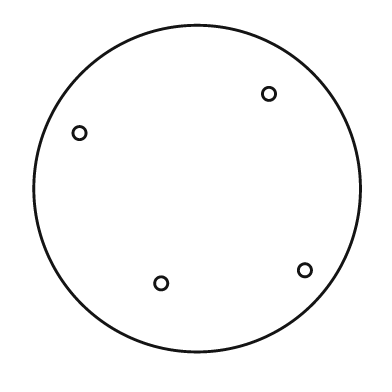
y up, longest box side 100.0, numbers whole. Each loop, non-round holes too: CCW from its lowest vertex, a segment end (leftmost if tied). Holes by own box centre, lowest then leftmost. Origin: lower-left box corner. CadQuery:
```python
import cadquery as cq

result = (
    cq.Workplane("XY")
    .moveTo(50.0, 50.0)
    .circle(50.0)
    .moveTo(39.0, 21.0)
    .circle(2.0)
    .moveTo(83.0, 25.0)
    .circle(2.0)
    .moveTo(14.0, 67.0)
    .circle(2.0)
    .moveTo(72.0, 79.0)
    .circle(2.0)
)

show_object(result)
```